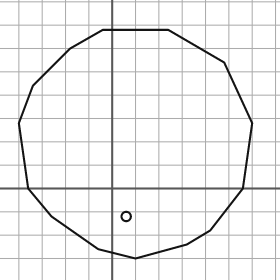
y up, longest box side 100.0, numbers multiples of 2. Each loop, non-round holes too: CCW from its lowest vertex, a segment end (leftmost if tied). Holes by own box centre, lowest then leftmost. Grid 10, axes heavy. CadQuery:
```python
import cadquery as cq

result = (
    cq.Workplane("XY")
    .moveTo(10.0, -30.0)
    .lineTo(32.0, -24.0)
    .lineTo(42.0, -18.0)
    .lineTo(56.0, 0.0)
    .lineTo(60.0, 28.0)
    .lineTo(48.0, 54.0)
    .lineTo(24.0, 68.0)
    .lineTo(-4.0, 68.0)
    .lineTo(-18.0, 60.0)
    .lineTo(-34.0, 44.0)
    .lineTo(-40.0, 28.0)
    .lineTo(-36.0, 0.0)
    .lineTo(-26.0, -12.0)
    .lineTo(-6.0, -26.0)
    .close()
    .moveTo(6.0, -12.0)
    .circle(2.0)
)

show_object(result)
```